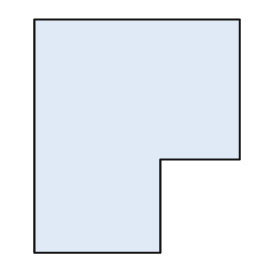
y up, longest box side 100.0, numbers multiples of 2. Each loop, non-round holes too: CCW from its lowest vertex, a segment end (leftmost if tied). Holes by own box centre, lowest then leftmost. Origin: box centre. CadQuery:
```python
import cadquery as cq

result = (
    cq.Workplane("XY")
    .moveTo(-44.0, -50.0)
    .lineTo(10.0, -50.0)
    .lineTo(10.0, -10.0)
    .lineTo(44.0, -10.0)
    .lineTo(44.0, 50.0)
    .lineTo(-44.0, 50.0)
    .close()
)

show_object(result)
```